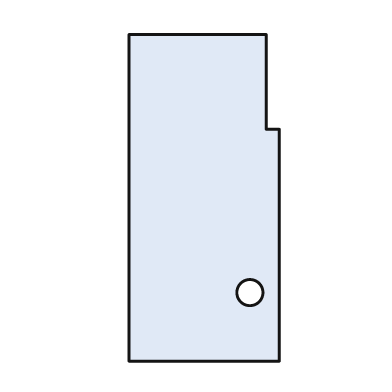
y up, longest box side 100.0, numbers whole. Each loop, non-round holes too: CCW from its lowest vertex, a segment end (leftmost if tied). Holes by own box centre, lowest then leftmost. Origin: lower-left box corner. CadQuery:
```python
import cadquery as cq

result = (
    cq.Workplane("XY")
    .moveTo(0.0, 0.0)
    .lineTo(46.0, 0.0)
    .lineTo(46.0, 71.0)
    .lineTo(42.0, 71.0)
    .lineTo(42.0, 100.0)
    .lineTo(0.0, 100.0)
    .close()
    .moveTo(37.0, 21.0)
    .circle(4.0)
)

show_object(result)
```